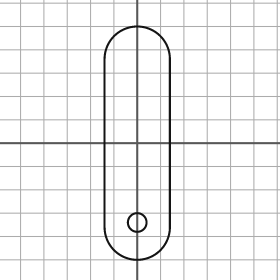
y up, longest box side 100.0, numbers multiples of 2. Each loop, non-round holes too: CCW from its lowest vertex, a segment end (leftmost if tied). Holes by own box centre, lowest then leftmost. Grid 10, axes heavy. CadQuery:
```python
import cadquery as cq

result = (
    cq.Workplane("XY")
    .moveTo(-14.0, -36.0)
    .threePointArc((0.0, -50.0), (14.0, -36.0))
    .lineTo(14.0, 36.0)
    .threePointArc((0.0, 50.0), (-14.0, 36.0))
    .close()
    .moveTo(0.0, -34.0)
    .circle(4.0)
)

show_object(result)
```